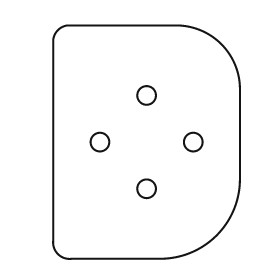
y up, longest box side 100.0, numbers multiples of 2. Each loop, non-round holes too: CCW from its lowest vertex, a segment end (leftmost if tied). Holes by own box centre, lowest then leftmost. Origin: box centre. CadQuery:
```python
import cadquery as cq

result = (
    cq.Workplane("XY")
    .moveTo(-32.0, -50.0)
    .lineTo(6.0, -50.0)
    .threePointArc((30.0, -40.0), (40.0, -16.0))
    .lineTo(40.0, 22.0)
    .threePointArc((32.0, 42.0), (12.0, 50.0))
    .lineTo(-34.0, 50.0)
    .threePointArc((-38.0, 48.0), (-40.0, 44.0))
    .lineTo(-40.0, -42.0)
    .threePointArc((-38.0, -48.0), (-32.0, -50.0))
    .close()
    .moveTo(0.0, -20.0)
    .circle(4.0)
    .moveTo(-20.0, 0.0)
    .circle(4.0)
    .moveTo(20.0, 0.0)
    .circle(4.0)
    .moveTo(0.0, 20.0)
    .circle(4.0)
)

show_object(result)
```